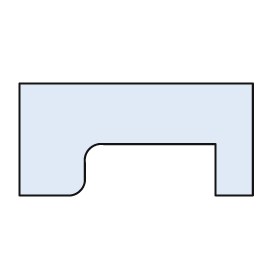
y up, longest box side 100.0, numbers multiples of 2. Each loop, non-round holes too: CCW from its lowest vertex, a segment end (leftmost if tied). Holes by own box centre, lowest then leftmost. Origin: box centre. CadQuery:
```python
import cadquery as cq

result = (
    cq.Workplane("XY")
    .moveTo(-50.0, -24.0)
    .lineTo(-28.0, -24.0)
    .threePointArc((-24.0, -22.0), (-22.0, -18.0))
    .lineTo(-22.0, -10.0)
    .threePointArc((-20.0, -4.0), (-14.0, -2.0))
    .lineTo(34.0, -2.0)
    .lineTo(34.0, -24.0)
    .lineTo(50.0, -24.0)
    .lineTo(50.0, 24.0)
    .lineTo(-50.0, 24.0)
    .close()
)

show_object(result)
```